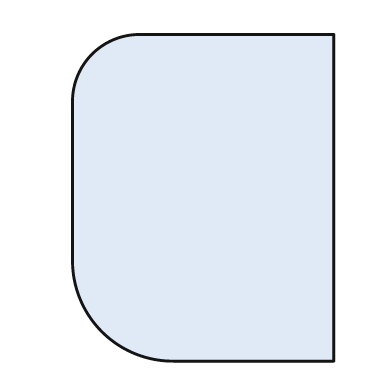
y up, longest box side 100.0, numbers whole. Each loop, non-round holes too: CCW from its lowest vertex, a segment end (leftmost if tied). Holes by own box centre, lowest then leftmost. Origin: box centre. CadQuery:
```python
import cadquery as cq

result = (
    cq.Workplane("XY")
    .moveTo(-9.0, -50.0)
    .lineTo(40.0, -50.0)
    .lineTo(40.0, 50.0)
    .lineTo(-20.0, 50.0)
    .threePointArc((-34.0, 44.0), (-40.0, 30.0))
    .lineTo(-40.0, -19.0)
    .threePointArc((-31.0, -41.0), (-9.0, -50.0))
    .close()
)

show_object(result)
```